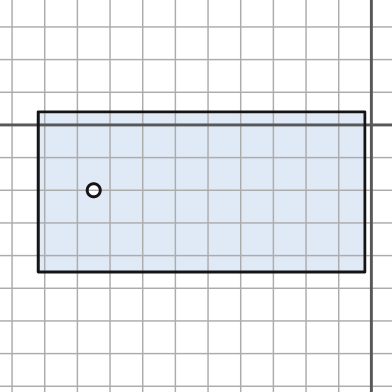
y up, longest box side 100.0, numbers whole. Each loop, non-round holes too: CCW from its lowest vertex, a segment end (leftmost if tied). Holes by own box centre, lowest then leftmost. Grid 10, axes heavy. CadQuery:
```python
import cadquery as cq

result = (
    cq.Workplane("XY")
    .moveTo(-102.0, -45.0)
    .lineTo(-2.0, -45.0)
    .lineTo(-2.0, 4.0)
    .lineTo(-102.0, 4.0)
    .close()
    .moveTo(-85.0, -20.0)
    .circle(2.0)
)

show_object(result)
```